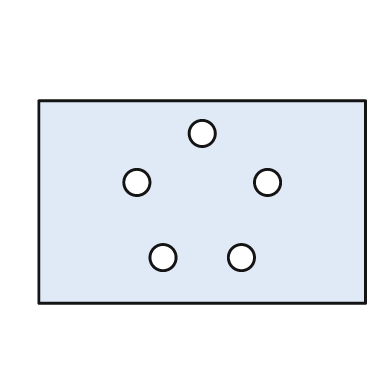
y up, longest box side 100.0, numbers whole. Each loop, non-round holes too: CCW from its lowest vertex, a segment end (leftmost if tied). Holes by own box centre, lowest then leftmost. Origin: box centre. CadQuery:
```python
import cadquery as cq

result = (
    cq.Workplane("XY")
    .moveTo(-50.0, -31.0)
    .lineTo(50.0, -31.0)
    .lineTo(50.0, 31.0)
    .lineTo(-50.0, 31.0)
    .close()
    .moveTo(-12.0, -17.0)
    .circle(4.0)
    .moveTo(12.0, -17.0)
    .circle(4.0)
    .moveTo(-20.0, 6.0)
    .circle(4.0)
    .moveTo(20.0, 6.0)
    .circle(4.0)
    .moveTo(0.0, 21.0)
    .circle(4.0)
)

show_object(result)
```